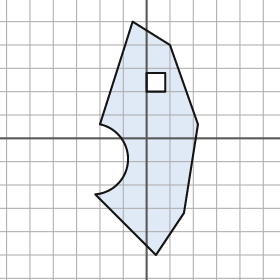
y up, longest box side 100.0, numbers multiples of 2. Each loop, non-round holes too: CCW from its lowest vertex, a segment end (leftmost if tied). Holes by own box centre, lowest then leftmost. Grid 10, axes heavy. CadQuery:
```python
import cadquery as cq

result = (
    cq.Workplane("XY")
    .moveTo(4.0, -50.0)
    .lineTo(16.0, -32.0)
    .lineTo(22.0, 6.0)
    .lineTo(10.0, 40.0)
    .lineTo(-6.0, 50.0)
    .lineTo(-20.0, 6.0)
    .threePointArc((-8.0, -10.0), (-22.0, -24.0))
    .close()
    .moveTo(0.0, 20.0)
    .lineTo(8.0, 20.0)
    .lineTo(8.0, 28.0)
    .lineTo(0.0, 28.0)
    .close()
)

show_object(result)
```